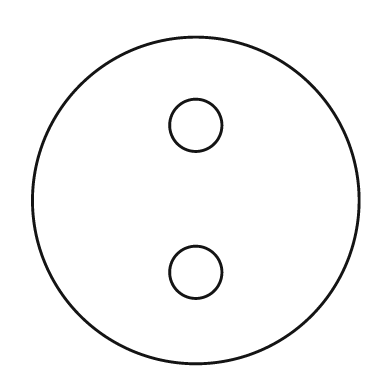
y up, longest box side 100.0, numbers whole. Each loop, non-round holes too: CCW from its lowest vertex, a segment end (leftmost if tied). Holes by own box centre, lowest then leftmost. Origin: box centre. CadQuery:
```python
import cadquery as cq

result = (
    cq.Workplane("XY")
    .moveTo(0.0, 0.0)
    .circle(50.0)
    .moveTo(0.0, -22.0)
    .circle(8.0)
    .moveTo(0.0, 23.0)
    .circle(8.0)
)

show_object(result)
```